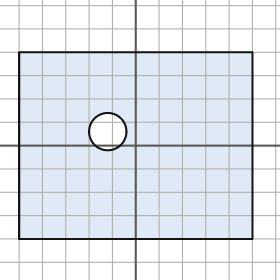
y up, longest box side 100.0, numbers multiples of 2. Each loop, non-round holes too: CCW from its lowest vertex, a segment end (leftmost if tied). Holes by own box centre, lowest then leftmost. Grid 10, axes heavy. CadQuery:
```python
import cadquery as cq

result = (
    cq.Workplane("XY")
    .moveTo(-50.0, -40.0)
    .lineTo(50.0, -40.0)
    .lineTo(50.0, 40.0)
    .lineTo(-50.0, 40.0)
    .close()
    .moveTo(-12.0, 6.0)
    .circle(8.0)
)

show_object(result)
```